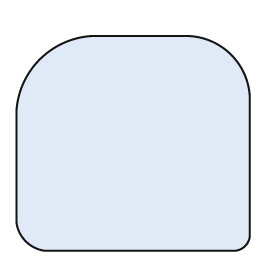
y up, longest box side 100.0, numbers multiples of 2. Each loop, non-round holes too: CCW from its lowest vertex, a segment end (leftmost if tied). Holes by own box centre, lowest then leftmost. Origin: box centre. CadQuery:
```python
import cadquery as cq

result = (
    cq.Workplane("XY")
    .moveTo(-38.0, -46.0)
    .lineTo(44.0, -46.0)
    .threePointArc((48.0, -44.0), (50.0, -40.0))
    .lineTo(50.0, 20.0)
    .threePointArc((42.0, 38.0), (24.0, 46.0))
    .lineTo(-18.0, 46.0)
    .threePointArc((-40.0, 36.0), (-50.0, 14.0))
    .lineTo(-50.0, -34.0)
    .threePointArc((-46.0, -42.0), (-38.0, -46.0))
    .close()
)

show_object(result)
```